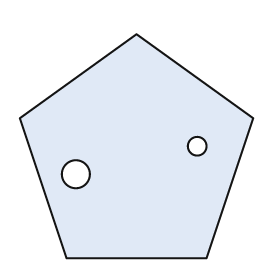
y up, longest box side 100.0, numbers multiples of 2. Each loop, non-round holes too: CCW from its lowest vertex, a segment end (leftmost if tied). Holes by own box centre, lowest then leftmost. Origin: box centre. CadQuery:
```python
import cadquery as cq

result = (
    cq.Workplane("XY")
    .moveTo(-30.0, -48.0)
    .lineTo(30.0, -48.0)
    .lineTo(50.0, 12.0)
    .lineTo(0.0, 48.0)
    .lineTo(-50.0, 12.0)
    .close()
    .moveTo(-26.0, -12.0)
    .circle(6.0)
    .moveTo(26.0, 0.0)
    .circle(4.0)
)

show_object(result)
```